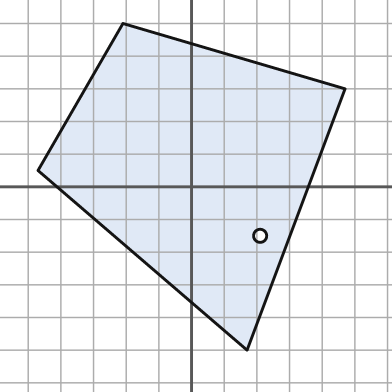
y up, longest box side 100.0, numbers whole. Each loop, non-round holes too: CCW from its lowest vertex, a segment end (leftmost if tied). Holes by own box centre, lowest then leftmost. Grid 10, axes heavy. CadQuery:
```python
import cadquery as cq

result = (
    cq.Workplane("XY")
    .moveTo(17.0, -50.0)
    .lineTo(47.0, 30.0)
    .lineTo(-21.0, 50.0)
    .lineTo(-47.0, 5.0)
    .close()
    .moveTo(21.0, -15.0)
    .circle(2.0)
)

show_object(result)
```